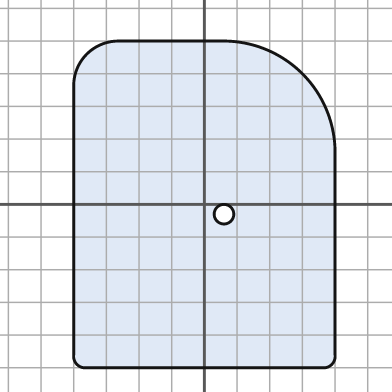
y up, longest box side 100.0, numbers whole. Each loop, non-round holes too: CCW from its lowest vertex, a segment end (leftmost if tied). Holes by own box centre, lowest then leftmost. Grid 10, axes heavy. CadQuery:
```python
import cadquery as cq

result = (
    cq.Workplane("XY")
    .moveTo(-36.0, -50.0)
    .lineTo(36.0, -50.0)
    .threePointArc((39.0, -49.0), (40.0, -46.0))
    .lineTo(40.0, 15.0)
    .threePointArc((30.0, 40.0), (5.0, 50.0))
    .lineTo(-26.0, 50.0)
    .threePointArc((-36.0, 46.0), (-40.0, 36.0))
    .lineTo(-40.0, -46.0)
    .threePointArc((-39.0, -49.0), (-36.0, -50.0))
    .close()
    .moveTo(6.0, -3.0)
    .circle(3.0)
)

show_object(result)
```